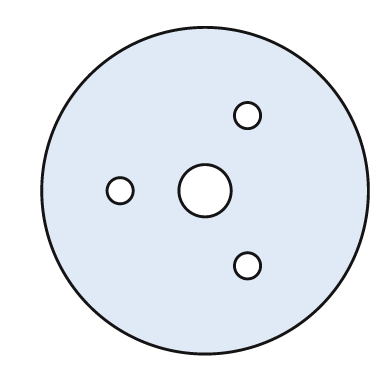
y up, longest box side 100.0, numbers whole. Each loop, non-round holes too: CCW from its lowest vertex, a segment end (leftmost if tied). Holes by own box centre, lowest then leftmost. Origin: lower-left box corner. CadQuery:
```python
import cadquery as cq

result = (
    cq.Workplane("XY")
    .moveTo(50.0, 50.0)
    .circle(50.0)
    .moveTo(63.0, 27.0)
    .circle(4.0)
    .moveTo(24.0, 50.0)
    .circle(4.0)
    .moveTo(50.0, 50.0)
    .circle(8.0)
    .moveTo(63.0, 73.0)
    .circle(4.0)
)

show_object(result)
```